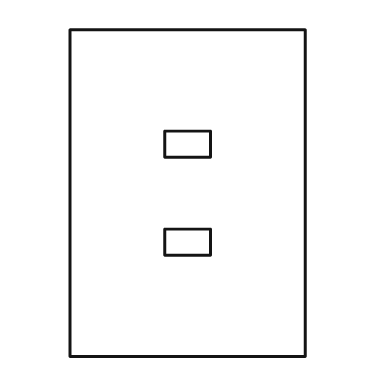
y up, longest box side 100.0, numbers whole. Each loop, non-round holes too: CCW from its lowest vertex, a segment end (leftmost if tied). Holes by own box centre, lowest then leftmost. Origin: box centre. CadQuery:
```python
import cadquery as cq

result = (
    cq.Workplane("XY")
    .moveTo(-36.0, -50.0)
    .lineTo(36.0, -50.0)
    .lineTo(36.0, 50.0)
    .lineTo(-36.0, 50.0)
    .close()
    .moveTo(-7.0, -19.0)
    .lineTo(7.0, -19.0)
    .lineTo(7.0, -11.0)
    .lineTo(-7.0, -11.0)
    .close()
    .moveTo(-7.0, 11.0)
    .lineTo(7.0, 11.0)
    .lineTo(7.0, 19.0)
    .lineTo(-7.0, 19.0)
    .close()
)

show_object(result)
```